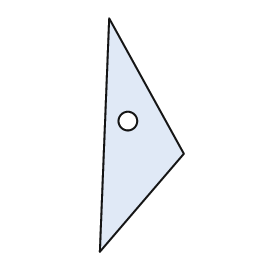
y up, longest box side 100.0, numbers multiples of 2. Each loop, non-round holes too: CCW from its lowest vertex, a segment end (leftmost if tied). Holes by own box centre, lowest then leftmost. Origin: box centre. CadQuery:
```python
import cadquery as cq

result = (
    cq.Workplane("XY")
    .moveTo(-18.0, -50.0)
    .lineTo(18.0, -8.0)
    .lineTo(-14.0, 50.0)
    .close()
    .moveTo(-6.0, 6.0)
    .circle(4.0)
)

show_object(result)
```